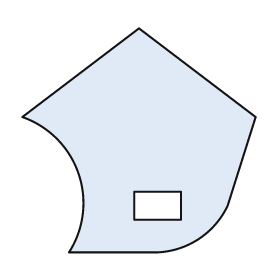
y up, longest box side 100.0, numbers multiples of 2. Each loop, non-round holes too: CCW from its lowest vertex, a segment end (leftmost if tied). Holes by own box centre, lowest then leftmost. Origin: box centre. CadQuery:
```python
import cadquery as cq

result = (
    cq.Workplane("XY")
    .moveTo(-30.0, -48.0)
    .lineTo(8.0, -48.0)
    .threePointArc((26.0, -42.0), (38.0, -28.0))
    .lineTo(50.0, 10.0)
    .lineTo(0.0, 48.0)
    .lineTo(-50.0, 10.0)
    .threePointArc((-26.0, -14.0), (-30.0, -48.0))
    .close()
    .moveTo(-2.0, -34.0)
    .lineTo(18.0, -34.0)
    .lineTo(18.0, -22.0)
    .lineTo(-2.0, -22.0)
    .close()
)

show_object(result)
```